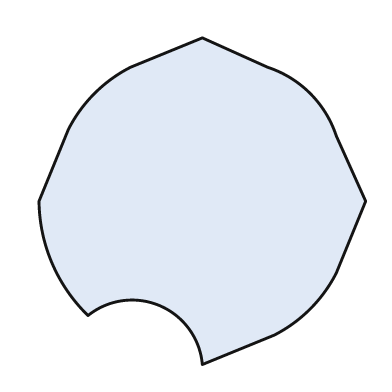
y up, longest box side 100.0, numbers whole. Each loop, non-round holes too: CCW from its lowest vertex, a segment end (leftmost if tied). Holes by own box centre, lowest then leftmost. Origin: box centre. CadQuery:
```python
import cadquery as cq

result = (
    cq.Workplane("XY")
    .moveTo(0.0, -50.0)
    .lineTo(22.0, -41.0)
    .threePointArc((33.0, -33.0), (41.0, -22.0))
    .lineTo(50.0, 0.0)
    .lineTo(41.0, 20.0)
    .threePointArc((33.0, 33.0), (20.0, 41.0))
    .lineTo(0.0, 50.0)
    .lineTo(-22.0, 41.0)
    .threePointArc((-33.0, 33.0), (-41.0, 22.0))
    .lineTo(-50.0, 0.0)
    .threePointArc((-46.0, -19.0), (-35.0, -35.0))
    .threePointArc((-13.0, -32.0), (0.0, -50.0))
    .close()
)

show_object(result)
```